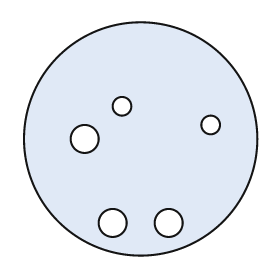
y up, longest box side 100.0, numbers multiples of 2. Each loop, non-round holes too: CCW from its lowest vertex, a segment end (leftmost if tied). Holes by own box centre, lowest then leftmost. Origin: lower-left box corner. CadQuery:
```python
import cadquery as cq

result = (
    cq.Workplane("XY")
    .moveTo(50.0, 50.0)
    .circle(50.0)
    .moveTo(38.0, 14.0)
    .circle(6.0)
    .moveTo(62.0, 14.0)
    .circle(6.0)
    .moveTo(26.0, 50.0)
    .circle(6.0)
    .moveTo(80.0, 56.0)
    .circle(4.0)
    .moveTo(42.0, 64.0)
    .circle(4.0)
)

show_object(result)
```